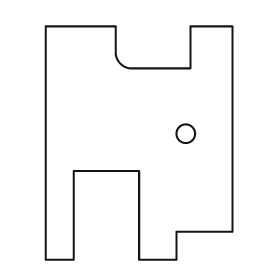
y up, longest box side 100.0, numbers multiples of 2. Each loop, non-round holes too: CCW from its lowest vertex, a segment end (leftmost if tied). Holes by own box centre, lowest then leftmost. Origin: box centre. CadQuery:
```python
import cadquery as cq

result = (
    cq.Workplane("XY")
    .moveTo(-40.0, -50.0)
    .lineTo(-28.0, -50.0)
    .lineTo(-28.0, -12.0)
    .lineTo(0.0, -12.0)
    .lineTo(0.0, -50.0)
    .lineTo(16.0, -50.0)
    .lineTo(16.0, -38.0)
    .lineTo(40.0, -38.0)
    .lineTo(40.0, 50.0)
    .lineTo(22.0, 50.0)
    .lineTo(22.0, 32.0)
    .lineTo(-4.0, 32.0)
    .threePointArc((-8.0, 34.0), (-10.0, 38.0))
    .lineTo(-10.0, 50.0)
    .lineTo(-40.0, 50.0)
    .close()
    .moveTo(20.0, 4.0)
    .circle(4.0)
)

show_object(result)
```